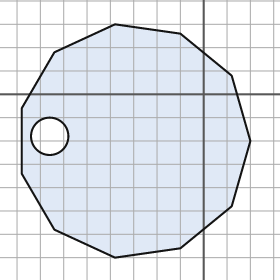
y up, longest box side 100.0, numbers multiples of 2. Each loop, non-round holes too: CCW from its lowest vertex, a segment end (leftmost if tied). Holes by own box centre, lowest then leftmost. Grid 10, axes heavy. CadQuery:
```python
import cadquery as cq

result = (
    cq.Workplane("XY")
    .moveTo(-38.0, -70.0)
    .lineTo(-10.0, -66.0)
    .lineTo(12.0, -48.0)
    .lineTo(20.0, -20.0)
    .lineTo(12.0, 8.0)
    .lineTo(-10.0, 26.0)
    .lineTo(-38.0, 30.0)
    .lineTo(-64.0, 18.0)
    .lineTo(-78.0, -6.0)
    .lineTo(-78.0, -34.0)
    .lineTo(-64.0, -58.0)
    .close()
    .moveTo(-66.0, -18.0)
    .circle(8.0)
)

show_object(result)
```